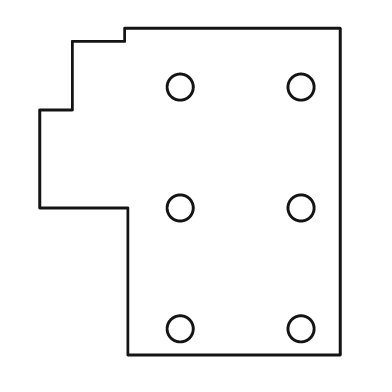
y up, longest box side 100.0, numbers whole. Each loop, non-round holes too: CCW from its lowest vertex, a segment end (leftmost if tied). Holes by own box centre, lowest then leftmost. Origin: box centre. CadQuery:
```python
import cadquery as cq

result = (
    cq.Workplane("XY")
    .moveTo(-19.0, -50.0)
    .lineTo(46.0, -50.0)
    .lineTo(46.0, 50.0)
    .lineTo(-20.0, 50.0)
    .lineTo(-20.0, 46.0)
    .lineTo(-36.0, 46.0)
    .lineTo(-36.0, 25.0)
    .lineTo(-46.0, 25.0)
    .lineTo(-46.0, -5.0)
    .lineTo(-19.0, -5.0)
    .close()
    .moveTo(-3.0, -42.0)
    .circle(4.0)
    .moveTo(34.0, -42.0)
    .circle(4.0)
    .moveTo(-3.0, -5.0)
    .circle(4.0)
    .moveTo(34.0, -5.0)
    .circle(4.0)
    .moveTo(-3.0, 32.0)
    .circle(4.0)
    .moveTo(34.0, 32.0)
    .circle(4.0)
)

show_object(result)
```